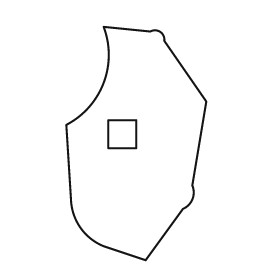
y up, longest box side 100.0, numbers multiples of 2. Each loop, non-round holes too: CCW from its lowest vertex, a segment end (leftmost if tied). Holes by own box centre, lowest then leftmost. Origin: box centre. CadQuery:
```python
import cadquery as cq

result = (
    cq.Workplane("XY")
    .moveTo(4.0, -50.0)
    .lineTo(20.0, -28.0)
    .threePointArc((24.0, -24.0), (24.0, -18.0))
    .lineTo(30.0, 18.0)
    .lineTo(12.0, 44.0)
    .threePointArc((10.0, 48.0), (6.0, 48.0))
    .lineTo(-14.0, 50.0)
    .threePointArc((-14.0, 26.0), (-30.0, 8.0))
    .lineTo(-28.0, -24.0)
    .threePointArc((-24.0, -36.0), (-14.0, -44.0))
    .close()
    .moveTo(-12.0, -2.0)
    .lineTo(0.0, -2.0)
    .lineTo(0.0, 10.0)
    .lineTo(-12.0, 10.0)
    .close()
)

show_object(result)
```